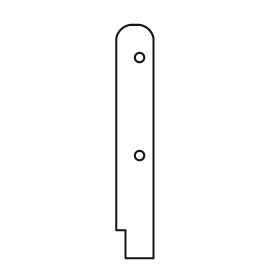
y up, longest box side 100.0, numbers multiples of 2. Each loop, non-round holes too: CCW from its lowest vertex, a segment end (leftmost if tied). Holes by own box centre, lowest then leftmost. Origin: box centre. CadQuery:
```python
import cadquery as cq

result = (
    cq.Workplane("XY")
    .moveTo(-4.0, -50.0)
    .lineTo(8.0, -50.0)
    .lineTo(8.0, 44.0)
    .threePointArc((6.0, 48.0), (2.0, 50.0))
    .lineTo(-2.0, 50.0)
    .threePointArc((-6.0, 48.0), (-8.0, 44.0))
    .lineTo(-8.0, -38.0)
    .lineTo(-4.0, -38.0)
    .close()
    .moveTo(2.0, -6.0)
    .circle(2.0)
    .moveTo(2.0, 36.0)
    .circle(2.0)
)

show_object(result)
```